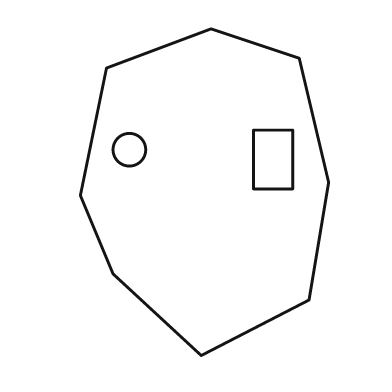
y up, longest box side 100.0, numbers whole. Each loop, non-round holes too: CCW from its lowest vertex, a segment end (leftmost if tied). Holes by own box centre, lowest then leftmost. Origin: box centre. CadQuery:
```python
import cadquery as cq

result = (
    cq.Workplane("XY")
    .moveTo(-1.0, -50.0)
    .lineTo(32.0, -33.0)
    .lineTo(38.0, 3.0)
    .lineTo(29.0, 41.0)
    .lineTo(2.0, 50.0)
    .lineTo(-30.0, 38.0)
    .lineTo(-38.0, -1.0)
    .lineTo(-28.0, -25.0)
    .close()
    .moveTo(15.0, 1.0)
    .lineTo(27.0, 1.0)
    .lineTo(27.0, 19.0)
    .lineTo(15.0, 19.0)
    .close()
    .moveTo(-23.0, 13.0)
    .circle(5.0)
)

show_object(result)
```